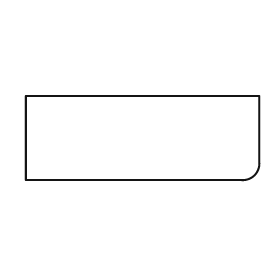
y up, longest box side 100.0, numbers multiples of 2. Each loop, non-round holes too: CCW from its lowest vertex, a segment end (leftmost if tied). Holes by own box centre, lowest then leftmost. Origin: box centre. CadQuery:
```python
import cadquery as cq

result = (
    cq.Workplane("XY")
    .moveTo(-50.0, -18.0)
    .lineTo(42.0, -18.0)
    .threePointArc((48.0, -16.0), (50.0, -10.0))
    .lineTo(50.0, 18.0)
    .lineTo(-50.0, 18.0)
    .close()
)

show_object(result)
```